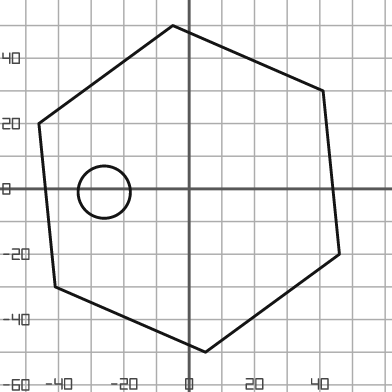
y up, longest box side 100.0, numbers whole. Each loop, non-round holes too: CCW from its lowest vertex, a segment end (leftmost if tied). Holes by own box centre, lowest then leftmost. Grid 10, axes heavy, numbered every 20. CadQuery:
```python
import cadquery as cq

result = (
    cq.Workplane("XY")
    .moveTo(5.0, -50.0)
    .lineTo(46.0, -20.0)
    .lineTo(41.0, 30.0)
    .lineTo(-5.0, 50.0)
    .lineTo(-46.0, 20.0)
    .lineTo(-41.0, -30.0)
    .close()
    .moveTo(-26.0, -1.0)
    .circle(8.0)
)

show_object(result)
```